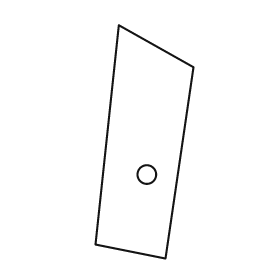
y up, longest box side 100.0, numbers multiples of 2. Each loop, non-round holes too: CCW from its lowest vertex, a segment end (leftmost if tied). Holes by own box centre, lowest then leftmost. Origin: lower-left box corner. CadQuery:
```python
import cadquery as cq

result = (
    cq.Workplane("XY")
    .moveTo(30.0, 0.0)
    .lineTo(42.0, 82.0)
    .lineTo(10.0, 100.0)
    .lineTo(0.0, 6.0)
    .close()
    .moveTo(22.0, 36.0)
    .circle(4.0)
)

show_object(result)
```